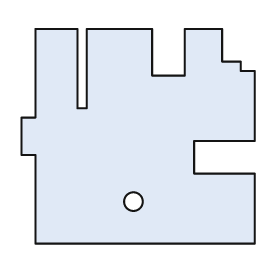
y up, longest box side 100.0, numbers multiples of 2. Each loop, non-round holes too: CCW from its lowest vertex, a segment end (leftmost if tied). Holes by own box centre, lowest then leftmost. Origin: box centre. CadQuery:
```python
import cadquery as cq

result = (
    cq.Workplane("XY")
    .moveTo(-44.0, -46.0)
    .lineTo(50.0, -46.0)
    .lineTo(50.0, -16.0)
    .lineTo(24.0, -16.0)
    .lineTo(24.0, -2.0)
    .lineTo(50.0, -2.0)
    .lineTo(50.0, 28.0)
    .lineTo(44.0, 28.0)
    .lineTo(44.0, 32.0)
    .lineTo(36.0, 32.0)
    .lineTo(36.0, 46.0)
    .lineTo(20.0, 46.0)
    .lineTo(20.0, 26.0)
    .lineTo(6.0, 26.0)
    .lineTo(6.0, 46.0)
    .lineTo(-22.0, 46.0)
    .lineTo(-22.0, 12.0)
    .lineTo(-26.0, 12.0)
    .lineTo(-26.0, 46.0)
    .lineTo(-44.0, 46.0)
    .lineTo(-44.0, 8.0)
    .lineTo(-50.0, 8.0)
    .lineTo(-50.0, -8.0)
    .lineTo(-44.0, -8.0)
    .close()
    .moveTo(-2.0, -28.0)
    .circle(4.0)
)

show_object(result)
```